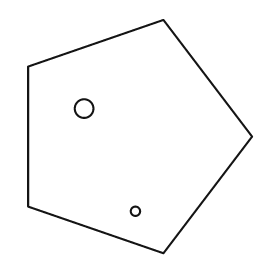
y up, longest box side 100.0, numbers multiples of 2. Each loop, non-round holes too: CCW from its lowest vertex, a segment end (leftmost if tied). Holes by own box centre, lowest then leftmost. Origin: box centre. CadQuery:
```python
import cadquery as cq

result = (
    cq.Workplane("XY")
    .moveTo(10.0, -50.0)
    .lineTo(48.0, 0.0)
    .lineTo(10.0, 50.0)
    .lineTo(-48.0, 30.0)
    .lineTo(-48.0, -30.0)
    .close()
    .moveTo(-2.0, -32.0)
    .circle(2.0)
    .moveTo(-24.0, 12.0)
    .circle(4.0)
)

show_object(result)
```